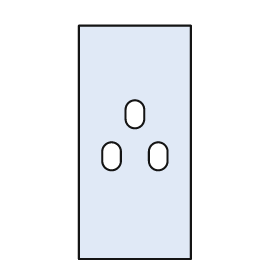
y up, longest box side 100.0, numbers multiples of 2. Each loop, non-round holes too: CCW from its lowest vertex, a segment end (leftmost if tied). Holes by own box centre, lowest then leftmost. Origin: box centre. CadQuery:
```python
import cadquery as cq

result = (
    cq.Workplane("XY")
    .moveTo(-24.0, -50.0)
    .lineTo(24.0, -50.0)
    .lineTo(24.0, 50.0)
    .lineTo(-24.0, 50.0)
    .close()
    .moveTo(-14.0, -8.0)
    .threePointArc((-10.0, -12.0), (-6.0, -8.0))
    .lineTo(-6.0, -4.0)
    .threePointArc((-10.0, 0.0), (-14.0, -4.0))
    .close()
    .moveTo(6.0, -8.0)
    .threePointArc((10.0, -12.0), (14.0, -8.0))
    .lineTo(14.0, -4.0)
    .threePointArc((10.0, 0.0), (6.0, -4.0))
    .close()
    .moveTo(-4.0, 10.0)
    .threePointArc((0.0, 6.0), (4.0, 10.0))
    .lineTo(4.0, 14.0)
    .threePointArc((0.0, 18.0), (-4.0, 14.0))
    .close()
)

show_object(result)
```